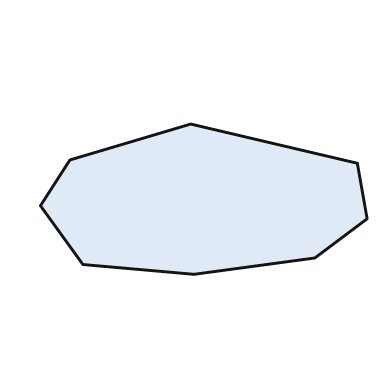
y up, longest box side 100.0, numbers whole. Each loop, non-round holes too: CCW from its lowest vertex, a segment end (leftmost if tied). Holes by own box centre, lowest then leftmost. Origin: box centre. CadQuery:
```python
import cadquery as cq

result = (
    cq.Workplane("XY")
    .moveTo(-3.0, -23.0)
    .lineTo(34.0, -18.0)
    .lineTo(50.0, -6.0)
    .lineTo(47.0, 11.0)
    .lineTo(-4.0, 23.0)
    .lineTo(-41.0, 12.0)
    .lineTo(-50.0, -2.0)
    .lineTo(-37.0, -20.0)
    .close()
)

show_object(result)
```